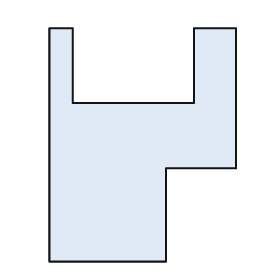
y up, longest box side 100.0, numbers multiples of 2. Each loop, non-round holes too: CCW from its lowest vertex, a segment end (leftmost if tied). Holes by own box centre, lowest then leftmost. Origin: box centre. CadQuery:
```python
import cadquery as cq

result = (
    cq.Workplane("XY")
    .moveTo(-40.0, -50.0)
    .lineTo(10.0, -50.0)
    .lineTo(10.0, -10.0)
    .lineTo(40.0, -10.0)
    .lineTo(40.0, 50.0)
    .lineTo(22.0, 50.0)
    .lineTo(22.0, 18.0)
    .lineTo(-30.0, 18.0)
    .lineTo(-30.0, 50.0)
    .lineTo(-40.0, 50.0)
    .close()
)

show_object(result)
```